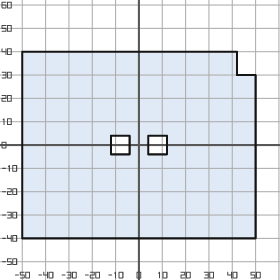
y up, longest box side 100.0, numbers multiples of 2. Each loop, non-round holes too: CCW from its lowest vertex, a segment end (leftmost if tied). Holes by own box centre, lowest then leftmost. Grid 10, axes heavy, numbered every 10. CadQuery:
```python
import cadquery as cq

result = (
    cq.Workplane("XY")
    .moveTo(-50.0, -40.0)
    .lineTo(50.0, -40.0)
    .lineTo(50.0, 30.0)
    .lineTo(42.0, 30.0)
    .lineTo(42.0, 40.0)
    .lineTo(-50.0, 40.0)
    .close()
    .moveTo(-12.0, -4.0)
    .lineTo(-4.0, -4.0)
    .lineTo(-4.0, 4.0)
    .lineTo(-12.0, 4.0)
    .close()
    .moveTo(4.0, -4.0)
    .lineTo(12.0, -4.0)
    .lineTo(12.0, 4.0)
    .lineTo(4.0, 4.0)
    .close()
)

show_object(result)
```